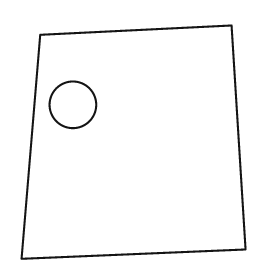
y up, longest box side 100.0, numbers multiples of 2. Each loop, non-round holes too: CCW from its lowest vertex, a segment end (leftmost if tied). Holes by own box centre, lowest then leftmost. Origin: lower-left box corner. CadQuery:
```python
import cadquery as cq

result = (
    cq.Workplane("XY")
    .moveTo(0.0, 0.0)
    .lineTo(96.0, 4.0)
    .lineTo(90.0, 100.0)
    .lineTo(8.0, 96.0)
    .close()
    .moveTo(22.0, 66.0)
    .circle(10.0)
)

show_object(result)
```